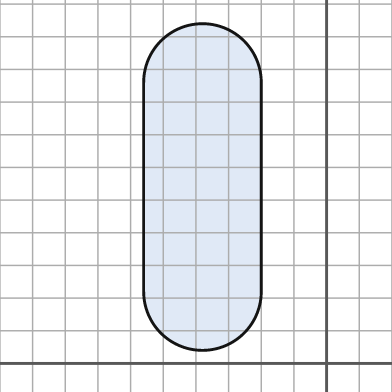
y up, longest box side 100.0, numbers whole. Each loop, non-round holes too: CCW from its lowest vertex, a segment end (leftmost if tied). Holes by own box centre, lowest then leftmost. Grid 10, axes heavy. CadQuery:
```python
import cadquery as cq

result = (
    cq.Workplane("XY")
    .moveTo(-56.0, 22.0)
    .threePointArc((-38.0, 4.0), (-20.0, 22.0))
    .lineTo(-20.0, 86.0)
    .threePointArc((-38.0, 104.0), (-56.0, 86.0))
    .close()
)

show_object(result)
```